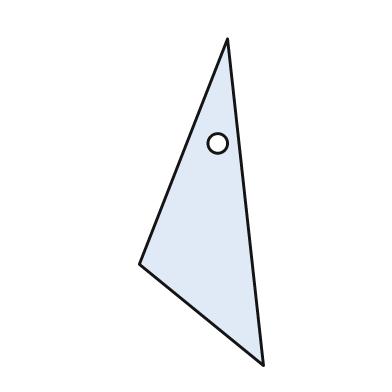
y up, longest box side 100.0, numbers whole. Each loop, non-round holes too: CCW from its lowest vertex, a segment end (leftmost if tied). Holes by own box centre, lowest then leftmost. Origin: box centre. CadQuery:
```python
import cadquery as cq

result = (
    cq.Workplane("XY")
    .moveTo(19.0, -50.0)
    .lineTo(8.0, 50.0)
    .lineTo(-19.0, -19.0)
    .close()
    .moveTo(5.0, 18.0)
    .circle(3.0)
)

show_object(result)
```